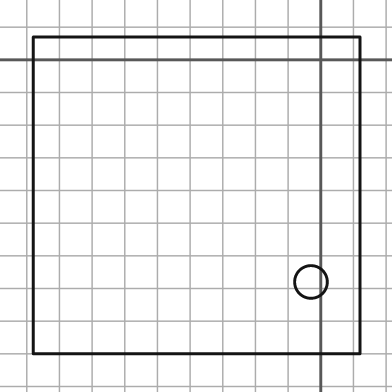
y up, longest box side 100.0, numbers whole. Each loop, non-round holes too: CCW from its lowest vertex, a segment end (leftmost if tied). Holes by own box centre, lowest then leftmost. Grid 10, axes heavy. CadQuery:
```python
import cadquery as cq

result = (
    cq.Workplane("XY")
    .moveTo(-88.0, -90.0)
    .lineTo(12.0, -90.0)
    .lineTo(12.0, 7.0)
    .lineTo(-88.0, 7.0)
    .close()
    .moveTo(-3.0, -68.0)
    .circle(5.0)
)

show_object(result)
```